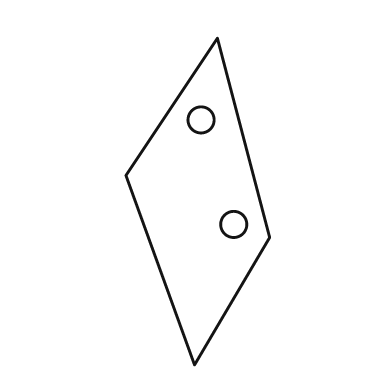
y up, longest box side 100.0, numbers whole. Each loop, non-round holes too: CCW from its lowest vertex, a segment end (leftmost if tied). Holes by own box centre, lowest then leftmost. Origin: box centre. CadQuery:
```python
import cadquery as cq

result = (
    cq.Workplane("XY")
    .moveTo(-1.0, -50.0)
    .lineTo(22.0, -11.0)
    .lineTo(6.0, 50.0)
    .lineTo(-22.0, 8.0)
    .close()
    .moveTo(11.0, -7.0)
    .circle(4.0)
    .moveTo(1.0, 25.0)
    .circle(4.0)
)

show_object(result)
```